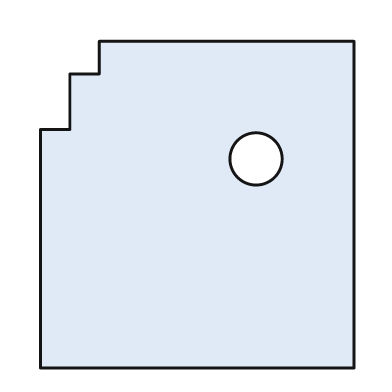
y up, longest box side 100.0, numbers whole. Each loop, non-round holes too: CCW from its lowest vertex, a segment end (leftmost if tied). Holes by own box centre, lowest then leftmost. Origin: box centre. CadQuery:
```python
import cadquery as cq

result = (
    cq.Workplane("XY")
    .moveTo(-48.0, -50.0)
    .lineTo(48.0, -50.0)
    .lineTo(48.0, 50.0)
    .lineTo(-30.0, 50.0)
    .lineTo(-30.0, 40.0)
    .lineTo(-39.0, 40.0)
    .lineTo(-39.0, 23.0)
    .lineTo(-48.0, 23.0)
    .close()
    .moveTo(18.0, 14.0)
    .circle(8.0)
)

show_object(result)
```